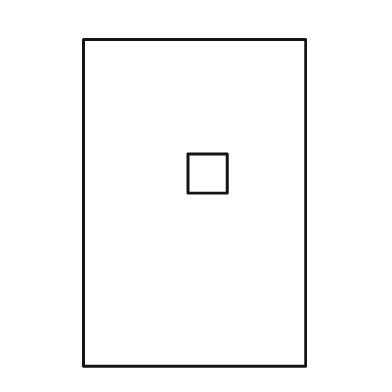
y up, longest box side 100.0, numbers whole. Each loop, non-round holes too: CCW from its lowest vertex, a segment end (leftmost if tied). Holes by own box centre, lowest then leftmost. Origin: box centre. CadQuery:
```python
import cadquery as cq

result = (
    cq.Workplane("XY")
    .moveTo(-34.0, -50.0)
    .lineTo(34.0, -50.0)
    .lineTo(34.0, 50.0)
    .lineTo(-34.0, 50.0)
    .close()
    .moveTo(-2.0, 3.0)
    .lineTo(10.0, 3.0)
    .lineTo(10.0, 15.0)
    .lineTo(-2.0, 15.0)
    .close()
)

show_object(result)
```